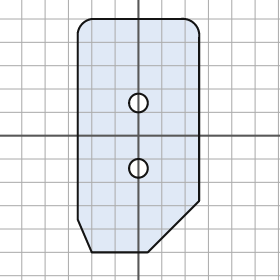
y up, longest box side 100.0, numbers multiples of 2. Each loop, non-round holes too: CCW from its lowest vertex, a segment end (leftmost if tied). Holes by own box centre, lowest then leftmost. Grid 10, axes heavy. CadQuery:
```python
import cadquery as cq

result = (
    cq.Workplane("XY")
    .moveTo(-20.0, -50.0)
    .lineTo(4.0, -50.0)
    .lineTo(26.0, -28.0)
    .lineTo(26.0, 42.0)
    .threePointArc((24.0, 48.0), (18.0, 50.0))
    .lineTo(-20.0, 50.0)
    .threePointArc((-24.0, 48.0), (-26.0, 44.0))
    .lineTo(-26.0, -36.0)
    .close()
    .moveTo(0.0, -14.0)
    .circle(4.0)
    .moveTo(0.0, 14.0)
    .circle(4.0)
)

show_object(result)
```